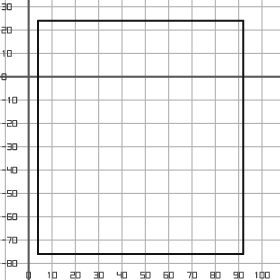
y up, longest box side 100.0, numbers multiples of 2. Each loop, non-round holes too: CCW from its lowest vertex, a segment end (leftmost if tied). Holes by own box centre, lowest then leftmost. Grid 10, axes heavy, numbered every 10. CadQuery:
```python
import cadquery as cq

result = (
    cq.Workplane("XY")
    .moveTo(4.0, -76.0)
    .lineTo(92.0, -76.0)
    .lineTo(92.0, 24.0)
    .lineTo(4.0, 24.0)
    .close()
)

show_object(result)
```